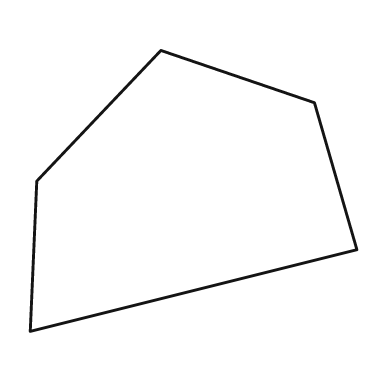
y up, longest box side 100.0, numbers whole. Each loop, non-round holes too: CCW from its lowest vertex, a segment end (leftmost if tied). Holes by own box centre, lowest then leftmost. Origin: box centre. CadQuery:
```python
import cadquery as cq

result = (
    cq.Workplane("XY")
    .moveTo(-50.0, -43.0)
    .lineTo(50.0, -18.0)
    .lineTo(37.0, 27.0)
    .lineTo(-10.0, 43.0)
    .lineTo(-48.0, 3.0)
    .close()
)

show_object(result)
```